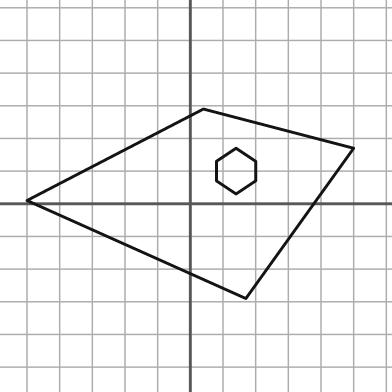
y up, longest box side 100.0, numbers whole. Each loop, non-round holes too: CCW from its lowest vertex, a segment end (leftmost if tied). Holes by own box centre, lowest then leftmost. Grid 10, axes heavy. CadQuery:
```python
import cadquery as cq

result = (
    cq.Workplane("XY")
    .moveTo(17.0, -29.0)
    .lineTo(50.0, 17.0)
    .lineTo(4.0, 29.0)
    .lineTo(-50.0, 1.0)
    .close()
    .moveTo(14.0, 3.0)
    .lineTo(20.0, 7.0)
    .lineTo(20.0, 13.0)
    .lineTo(14.0, 17.0)
    .lineTo(8.0, 13.0)
    .lineTo(8.0, 7.0)
    .close()
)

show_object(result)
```